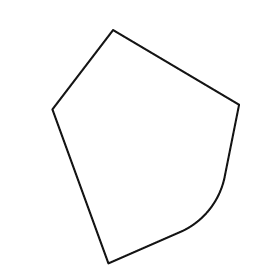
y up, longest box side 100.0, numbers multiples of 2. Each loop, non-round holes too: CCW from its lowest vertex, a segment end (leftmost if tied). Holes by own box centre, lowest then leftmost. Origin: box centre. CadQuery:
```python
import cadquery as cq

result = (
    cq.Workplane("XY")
    .moveTo(-16.0, -50.0)
    .lineTo(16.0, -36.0)
    .threePointArc((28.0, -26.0), (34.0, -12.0))
    .lineTo(40.0, 18.0)
    .lineTo(-14.0, 50.0)
    .lineTo(-40.0, 16.0)
    .close()
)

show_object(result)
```